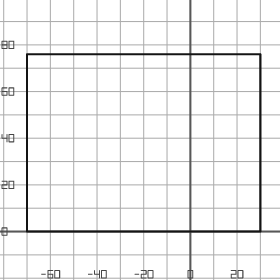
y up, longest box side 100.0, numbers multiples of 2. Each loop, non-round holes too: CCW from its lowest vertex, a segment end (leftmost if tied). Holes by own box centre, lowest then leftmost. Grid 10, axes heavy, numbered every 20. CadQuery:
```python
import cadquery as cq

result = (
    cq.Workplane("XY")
    .moveTo(-70.0, 0.0)
    .lineTo(30.0, 0.0)
    .lineTo(30.0, 76.0)
    .lineTo(-70.0, 76.0)
    .close()
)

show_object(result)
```